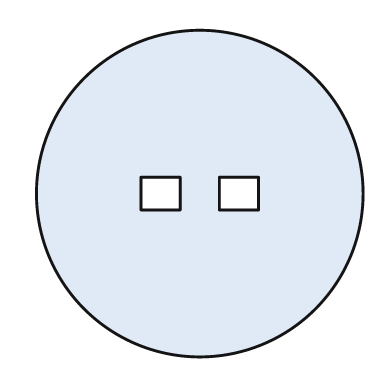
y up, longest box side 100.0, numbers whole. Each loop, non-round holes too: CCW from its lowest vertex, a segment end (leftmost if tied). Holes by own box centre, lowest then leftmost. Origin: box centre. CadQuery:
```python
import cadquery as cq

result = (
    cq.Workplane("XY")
    .moveTo(0.0, 0.0)
    .circle(50.0)
    .moveTo(-18.0, -5.0)
    .lineTo(-6.0, -5.0)
    .lineTo(-6.0, 5.0)
    .lineTo(-18.0, 5.0)
    .close()
    .moveTo(6.0, -5.0)
    .lineTo(18.0, -5.0)
    .lineTo(18.0, 5.0)
    .lineTo(6.0, 5.0)
    .close()
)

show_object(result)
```